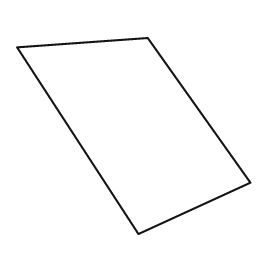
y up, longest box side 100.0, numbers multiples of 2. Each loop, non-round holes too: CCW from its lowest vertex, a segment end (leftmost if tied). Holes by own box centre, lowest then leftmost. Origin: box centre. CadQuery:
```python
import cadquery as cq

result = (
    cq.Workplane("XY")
    .moveTo(2.0, -42.0)
    .lineTo(50.0, -20.0)
    .lineTo(6.0, 42.0)
    .lineTo(-50.0, 38.0)
    .close()
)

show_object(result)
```